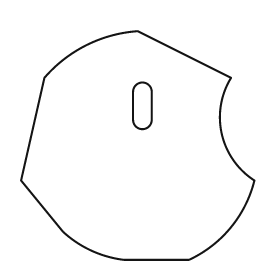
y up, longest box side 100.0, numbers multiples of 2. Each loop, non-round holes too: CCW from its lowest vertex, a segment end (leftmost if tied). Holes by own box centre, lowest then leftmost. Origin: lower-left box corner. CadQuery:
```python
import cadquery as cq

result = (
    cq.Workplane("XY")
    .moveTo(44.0, 0.0)
    .lineTo(72.0, 0.0)
    .threePointArc((90.0, 14.0), (100.0, 34.0))
    .threePointArc((86.0, 54.0), (90.0, 78.0))
    .lineTo(50.0, 98.0)
    .threePointArc((28.0, 92.0), (10.0, 78.0))
    .lineTo(0.0, 34.0)
    .lineTo(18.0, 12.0)
    .threePointArc((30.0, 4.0), (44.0, 0.0))
    .close()
    .moveTo(48.0, 60.0)
    .threePointArc((52.0, 56.0), (56.0, 60.0))
    .lineTo(56.0, 72.0)
    .threePointArc((52.0, 76.0), (48.0, 72.0))
    .close()
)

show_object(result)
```